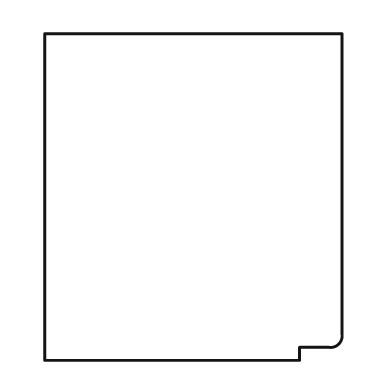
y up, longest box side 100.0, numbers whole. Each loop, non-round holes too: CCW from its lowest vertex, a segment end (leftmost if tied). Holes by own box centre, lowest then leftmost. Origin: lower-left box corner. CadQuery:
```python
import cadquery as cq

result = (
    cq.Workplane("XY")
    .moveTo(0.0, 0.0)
    .lineTo(78.0, 0.0)
    .lineTo(78.0, 4.0)
    .lineTo(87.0, 4.0)
    .threePointArc((90.0, 5.0), (91.0, 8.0))
    .lineTo(91.0, 100.0)
    .lineTo(0.0, 100.0)
    .close()
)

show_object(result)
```